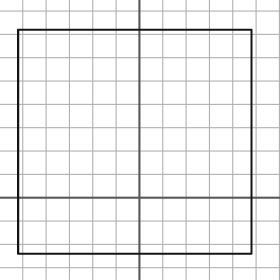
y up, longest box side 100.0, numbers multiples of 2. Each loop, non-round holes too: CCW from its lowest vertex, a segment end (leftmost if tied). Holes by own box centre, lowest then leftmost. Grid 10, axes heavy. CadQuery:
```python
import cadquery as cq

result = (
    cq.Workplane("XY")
    .moveTo(-52.0, -24.0)
    .lineTo(48.0, -24.0)
    .lineTo(48.0, 72.0)
    .lineTo(-52.0, 72.0)
    .close()
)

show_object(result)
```